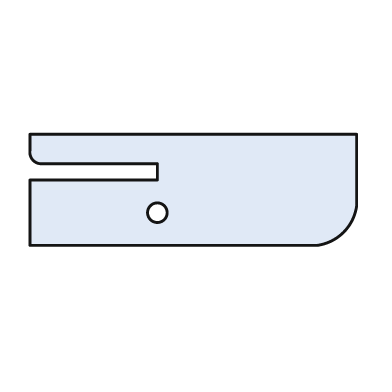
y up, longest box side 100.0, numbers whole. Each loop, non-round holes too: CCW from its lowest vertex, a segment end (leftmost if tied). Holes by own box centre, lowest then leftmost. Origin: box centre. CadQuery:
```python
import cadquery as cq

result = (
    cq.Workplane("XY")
    .moveTo(-50.0, -17.0)
    .lineTo(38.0, -17.0)
    .threePointArc((46.0, -13.0), (50.0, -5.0))
    .lineTo(50.0, 17.0)
    .lineTo(-50.0, 17.0)
    .lineTo(-50.0, 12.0)
    .threePointArc((-49.0, 9.0), (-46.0, 8.0))
    .lineTo(-11.0, 8.0)
    .lineTo(-11.0, 3.0)
    .lineTo(-50.0, 3.0)
    .close()
    .moveTo(-11.0, -7.0)
    .circle(3.0)
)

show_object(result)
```